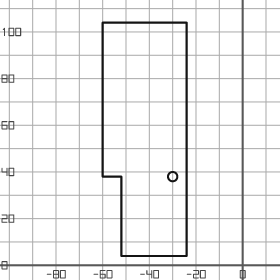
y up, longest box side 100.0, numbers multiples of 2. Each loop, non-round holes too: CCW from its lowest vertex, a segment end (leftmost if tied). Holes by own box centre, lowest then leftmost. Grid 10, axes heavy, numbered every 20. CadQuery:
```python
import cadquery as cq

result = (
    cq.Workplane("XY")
    .moveTo(-52.0, 4.0)
    .lineTo(-24.0, 4.0)
    .lineTo(-24.0, 104.0)
    .lineTo(-60.0, 104.0)
    .lineTo(-60.0, 38.0)
    .lineTo(-52.0, 38.0)
    .close()
    .moveTo(-30.0, 38.0)
    .circle(2.0)
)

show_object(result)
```